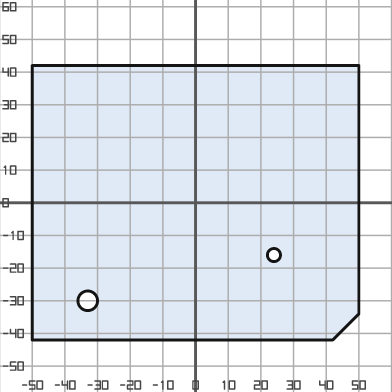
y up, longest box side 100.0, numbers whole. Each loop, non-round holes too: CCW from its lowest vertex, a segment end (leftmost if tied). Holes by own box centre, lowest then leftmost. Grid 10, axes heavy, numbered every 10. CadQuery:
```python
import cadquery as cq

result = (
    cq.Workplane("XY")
    .moveTo(-50.0, -42.0)
    .lineTo(42.0, -42.0)
    .lineTo(50.0, -34.0)
    .lineTo(50.0, 42.0)
    .lineTo(-50.0, 42.0)
    .close()
    .moveTo(-33.0, -30.0)
    .circle(3.0)
    .moveTo(24.0, -16.0)
    .circle(2.0)
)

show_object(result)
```